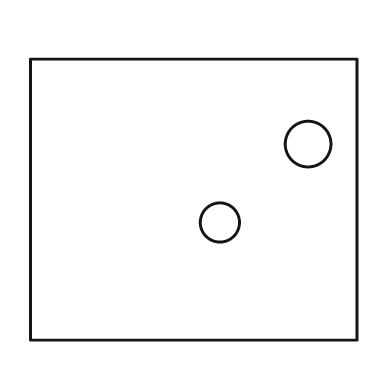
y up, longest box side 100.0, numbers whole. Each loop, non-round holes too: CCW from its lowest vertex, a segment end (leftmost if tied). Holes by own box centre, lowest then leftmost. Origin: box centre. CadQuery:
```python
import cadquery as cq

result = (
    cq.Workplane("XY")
    .moveTo(-50.0, -43.0)
    .lineTo(50.0, -43.0)
    .lineTo(50.0, 43.0)
    .lineTo(-50.0, 43.0)
    .close()
    .moveTo(8.0, -7.0)
    .circle(6.0)
    .moveTo(35.0, 17.0)
    .circle(7.0)
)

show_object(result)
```